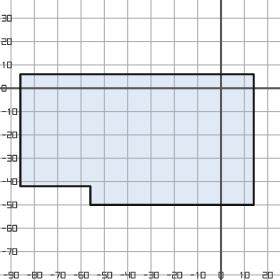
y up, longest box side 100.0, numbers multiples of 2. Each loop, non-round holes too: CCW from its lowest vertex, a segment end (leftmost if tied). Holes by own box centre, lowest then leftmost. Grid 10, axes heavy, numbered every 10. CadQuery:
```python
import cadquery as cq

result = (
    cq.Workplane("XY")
    .moveTo(-56.0, -50.0)
    .lineTo(14.0, -50.0)
    .lineTo(14.0, 6.0)
    .lineTo(-86.0, 6.0)
    .lineTo(-86.0, -42.0)
    .lineTo(-56.0, -42.0)
    .close()
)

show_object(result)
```